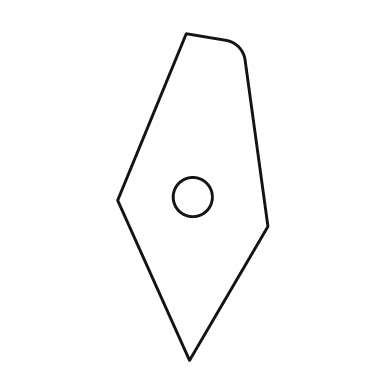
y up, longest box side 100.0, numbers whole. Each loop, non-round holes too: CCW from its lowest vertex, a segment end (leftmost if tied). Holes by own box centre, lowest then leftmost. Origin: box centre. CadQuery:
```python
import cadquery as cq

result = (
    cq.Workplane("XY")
    .moveTo(-1.0, -50.0)
    .lineTo(23.0, -9.0)
    .lineTo(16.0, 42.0)
    .threePointArc((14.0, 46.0), (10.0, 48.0))
    .lineTo(-2.0, 50.0)
    .lineTo(-23.0, -1.0)
    .close()
    .moveTo(0.0, 0.0)
    .circle(6.0)
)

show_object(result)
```